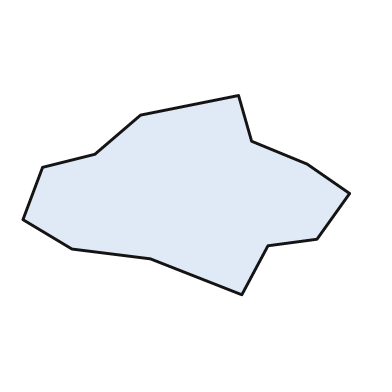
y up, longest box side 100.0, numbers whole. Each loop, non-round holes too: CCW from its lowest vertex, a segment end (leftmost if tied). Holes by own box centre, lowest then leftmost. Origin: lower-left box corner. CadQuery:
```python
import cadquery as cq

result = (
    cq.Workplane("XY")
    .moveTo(67.0, 0.0)
    .lineTo(75.0, 15.0)
    .lineTo(90.0, 17.0)
    .lineTo(100.0, 31.0)
    .lineTo(87.0, 40.0)
    .lineTo(70.0, 47.0)
    .lineTo(66.0, 61.0)
    .lineTo(36.0, 55.0)
    .lineTo(22.0, 43.0)
    .lineTo(6.0, 39.0)
    .lineTo(0.0, 23.0)
    .lineTo(15.0, 14.0)
    .lineTo(39.0, 11.0)
    .close()
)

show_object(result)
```